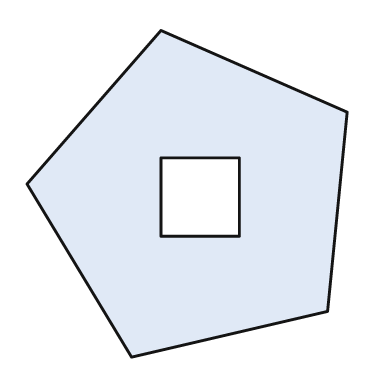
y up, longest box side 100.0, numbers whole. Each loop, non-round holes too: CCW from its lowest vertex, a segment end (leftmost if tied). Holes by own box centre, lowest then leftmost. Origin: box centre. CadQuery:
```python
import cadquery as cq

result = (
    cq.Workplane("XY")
    .moveTo(-17.0, -50.0)
    .lineTo(43.0, -36.0)
    .lineTo(49.0, 25.0)
    .lineTo(-8.0, 50.0)
    .lineTo(-49.0, 3.0)
    .close()
    .moveTo(-8.0, -13.0)
    .lineTo(16.0, -13.0)
    .lineTo(16.0, 11.0)
    .lineTo(-8.0, 11.0)
    .close()
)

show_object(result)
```